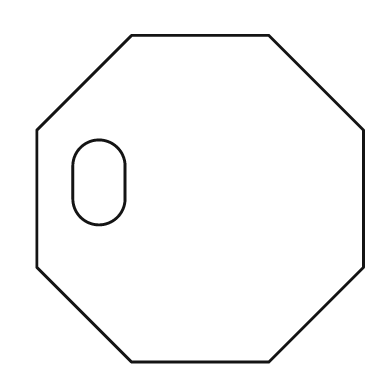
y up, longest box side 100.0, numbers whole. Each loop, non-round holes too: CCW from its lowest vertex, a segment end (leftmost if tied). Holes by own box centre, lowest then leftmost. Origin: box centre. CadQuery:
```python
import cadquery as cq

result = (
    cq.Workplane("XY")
    .moveTo(-21.0, -50.0)
    .lineTo(21.0, -50.0)
    .lineTo(50.0, -21.0)
    .lineTo(50.0, 21.0)
    .lineTo(21.0, 50.0)
    .lineTo(-21.0, 50.0)
    .lineTo(-50.0, 21.0)
    .lineTo(-50.0, -21.0)
    .close()
    .moveTo(-39.0, 0.0)
    .threePointArc((-31.0, -8.0), (-23.0, 0.0))
    .lineTo(-23.0, 10.0)
    .threePointArc((-31.0, 18.0), (-39.0, 10.0))
    .close()
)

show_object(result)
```